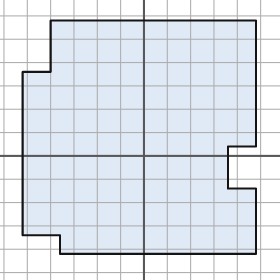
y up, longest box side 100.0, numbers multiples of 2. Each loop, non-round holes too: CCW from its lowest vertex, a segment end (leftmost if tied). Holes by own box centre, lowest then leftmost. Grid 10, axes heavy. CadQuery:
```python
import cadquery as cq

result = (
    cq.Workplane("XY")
    .moveTo(-36.0, -42.0)
    .lineTo(48.0, -42.0)
    .lineTo(48.0, -14.0)
    .lineTo(36.0, -14.0)
    .lineTo(36.0, 4.0)
    .lineTo(48.0, 4.0)
    .lineTo(48.0, 58.0)
    .lineTo(-40.0, 58.0)
    .lineTo(-40.0, 36.0)
    .lineTo(-52.0, 36.0)
    .lineTo(-52.0, -34.0)
    .lineTo(-36.0, -34.0)
    .close()
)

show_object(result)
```